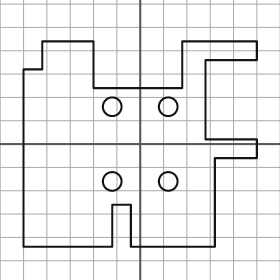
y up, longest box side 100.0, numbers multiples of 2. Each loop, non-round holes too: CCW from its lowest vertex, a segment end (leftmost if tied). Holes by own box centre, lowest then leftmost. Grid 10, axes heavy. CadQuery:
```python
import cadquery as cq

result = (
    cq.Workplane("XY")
    .moveTo(-50.0, -44.0)
    .lineTo(-12.0, -44.0)
    .lineTo(-12.0, -26.0)
    .lineTo(-4.0, -26.0)
    .lineTo(-4.0, -44.0)
    .lineTo(32.0, -44.0)
    .lineTo(32.0, -6.0)
    .lineTo(50.0, -6.0)
    .lineTo(50.0, 2.0)
    .lineTo(28.0, 2.0)
    .lineTo(28.0, 36.0)
    .lineTo(50.0, 36.0)
    .lineTo(50.0, 44.0)
    .lineTo(18.0, 44.0)
    .lineTo(18.0, 24.0)
    .lineTo(-20.0, 24.0)
    .lineTo(-20.0, 44.0)
    .lineTo(-42.0, 44.0)
    .lineTo(-42.0, 32.0)
    .lineTo(-50.0, 32.0)
    .close()
    .moveTo(-12.0, -16.0)
    .circle(4.0)
    .moveTo(12.0, -16.0)
    .circle(4.0)
    .moveTo(-12.0, 16.0)
    .circle(4.0)
    .moveTo(12.0, 16.0)
    .circle(4.0)
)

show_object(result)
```